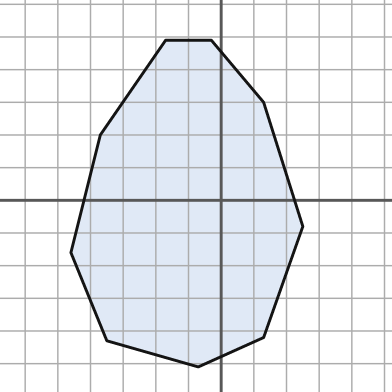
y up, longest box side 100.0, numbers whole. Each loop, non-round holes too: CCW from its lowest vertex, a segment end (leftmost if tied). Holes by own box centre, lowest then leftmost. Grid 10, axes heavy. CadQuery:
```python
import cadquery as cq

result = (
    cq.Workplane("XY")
    .moveTo(-7.0, -51.0)
    .lineTo(13.0, -42.0)
    .lineTo(25.0, -8.0)
    .lineTo(13.0, 30.0)
    .lineTo(-3.0, 49.0)
    .lineTo(-17.0, 49.0)
    .lineTo(-37.0, 20.0)
    .lineTo(-46.0, -16.0)
    .lineTo(-35.0, -43.0)
    .close()
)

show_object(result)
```